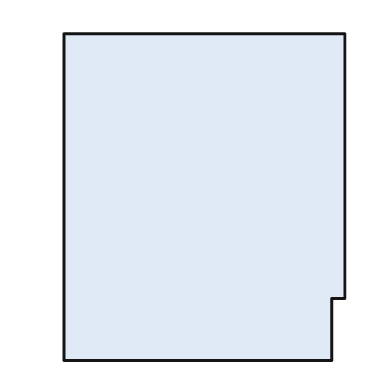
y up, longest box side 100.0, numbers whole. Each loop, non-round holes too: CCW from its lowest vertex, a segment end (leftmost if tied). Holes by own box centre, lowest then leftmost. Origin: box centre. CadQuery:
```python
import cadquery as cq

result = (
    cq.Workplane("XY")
    .moveTo(-43.0, -50.0)
    .lineTo(39.0, -50.0)
    .lineTo(39.0, -31.0)
    .lineTo(43.0, -31.0)
    .lineTo(43.0, 50.0)
    .lineTo(-43.0, 50.0)
    .close()
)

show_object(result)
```